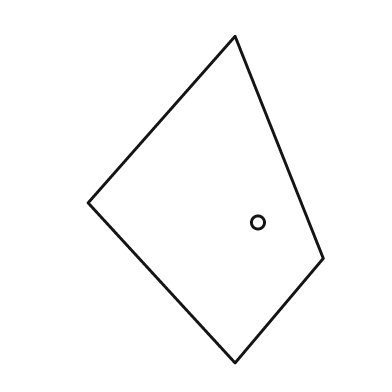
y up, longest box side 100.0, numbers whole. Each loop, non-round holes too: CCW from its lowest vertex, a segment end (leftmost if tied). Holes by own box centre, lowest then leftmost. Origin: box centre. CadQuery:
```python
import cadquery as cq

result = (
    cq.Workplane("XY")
    .moveTo(9.0, -50.0)
    .lineTo(36.0, -18.0)
    .lineTo(9.0, 50.0)
    .lineTo(-36.0, -1.0)
    .close()
    .moveTo(16.0, -7.0)
    .circle(2.0)
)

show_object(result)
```